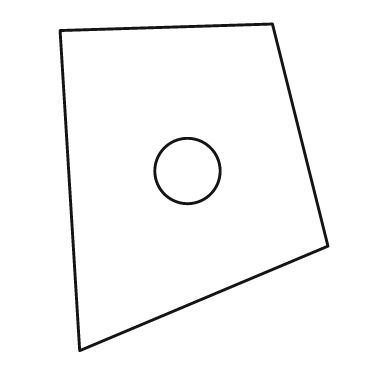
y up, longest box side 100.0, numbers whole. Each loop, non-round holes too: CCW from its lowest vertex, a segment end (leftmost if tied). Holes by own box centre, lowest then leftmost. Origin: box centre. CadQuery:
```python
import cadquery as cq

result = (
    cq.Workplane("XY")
    .moveTo(-35.0, -50.0)
    .lineTo(41.0, -18.0)
    .lineTo(24.0, 50.0)
    .lineTo(-41.0, 48.0)
    .close()
    .moveTo(-2.0, 5.0)
    .circle(10.0)
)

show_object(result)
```